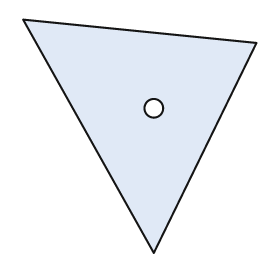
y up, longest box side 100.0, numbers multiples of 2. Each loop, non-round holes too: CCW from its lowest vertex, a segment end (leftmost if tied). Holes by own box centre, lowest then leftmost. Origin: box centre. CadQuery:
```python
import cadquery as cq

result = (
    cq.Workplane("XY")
    .moveTo(6.0, -50.0)
    .lineTo(50.0, 40.0)
    .lineTo(-50.0, 50.0)
    .close()
    .moveTo(6.0, 12.0)
    .circle(4.0)
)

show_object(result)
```